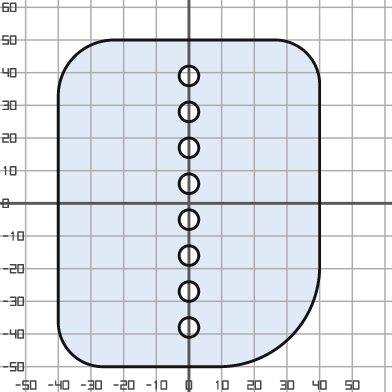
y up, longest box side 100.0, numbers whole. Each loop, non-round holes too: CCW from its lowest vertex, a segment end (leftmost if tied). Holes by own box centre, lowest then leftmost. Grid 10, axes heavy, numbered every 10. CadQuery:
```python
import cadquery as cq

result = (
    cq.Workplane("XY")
    .moveTo(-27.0, -50.0)
    .lineTo(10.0, -50.0)
    .threePointArc((31.0, -41.0), (40.0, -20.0))
    .lineTo(40.0, 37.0)
    .threePointArc((36.0, 46.0), (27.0, 50.0))
    .lineTo(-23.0, 50.0)
    .threePointArc((-35.0, 45.0), (-40.0, 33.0))
    .lineTo(-40.0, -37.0)
    .threePointArc((-36.0, -46.0), (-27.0, -50.0))
    .close()
    .moveTo(0.0, -38.0)
    .circle(3.0)
    .moveTo(0.0, -27.0)
    .circle(3.0)
    .moveTo(0.0, -16.0)
    .circle(3.0)
    .moveTo(0.0, -5.0)
    .circle(3.0)
    .moveTo(0.0, 6.0)
    .circle(3.0)
    .moveTo(0.0, 17.0)
    .circle(3.0)
    .moveTo(0.0, 28.0)
    .circle(3.0)
    .moveTo(0.0, 39.0)
    .circle(3.0)
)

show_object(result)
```